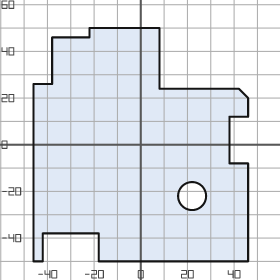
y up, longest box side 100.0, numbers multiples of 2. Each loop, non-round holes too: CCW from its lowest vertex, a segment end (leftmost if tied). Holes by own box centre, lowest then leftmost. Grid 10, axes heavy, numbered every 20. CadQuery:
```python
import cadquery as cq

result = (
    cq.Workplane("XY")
    .moveTo(-46.0, -50.0)
    .lineTo(-42.0, -50.0)
    .lineTo(-42.0, -38.0)
    .lineTo(-18.0, -38.0)
    .lineTo(-18.0, -50.0)
    .lineTo(46.0, -50.0)
    .lineTo(46.0, -8.0)
    .lineTo(38.0, -8.0)
    .lineTo(38.0, 12.0)
    .lineTo(46.0, 12.0)
    .lineTo(46.0, 20.0)
    .lineTo(42.0, 24.0)
    .lineTo(8.0, 24.0)
    .lineTo(8.0, 50.0)
    .lineTo(-22.0, 50.0)
    .lineTo(-22.0, 46.0)
    .lineTo(-38.0, 46.0)
    .lineTo(-38.0, 26.0)
    .lineTo(-46.0, 26.0)
    .close()
    .moveTo(22.0, -22.0)
    .circle(6.0)
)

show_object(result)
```